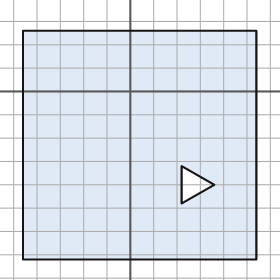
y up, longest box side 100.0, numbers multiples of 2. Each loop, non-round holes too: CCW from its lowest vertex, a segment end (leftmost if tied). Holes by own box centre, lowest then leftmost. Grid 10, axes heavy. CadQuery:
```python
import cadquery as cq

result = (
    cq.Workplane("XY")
    .moveTo(-46.0, -72.0)
    .lineTo(54.0, -72.0)
    .lineTo(54.0, 26.0)
    .lineTo(-46.0, 26.0)
    .close()
    .moveTo(22.0, -48.0)
    .lineTo(36.0, -40.0)
    .lineTo(22.0, -32.0)
    .close()
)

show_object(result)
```